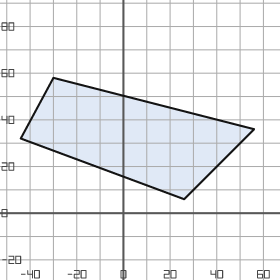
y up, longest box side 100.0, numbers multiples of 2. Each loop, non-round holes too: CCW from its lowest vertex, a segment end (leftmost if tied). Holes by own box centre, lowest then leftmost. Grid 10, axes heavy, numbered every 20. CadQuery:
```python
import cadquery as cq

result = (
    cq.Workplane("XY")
    .moveTo(26.0, 6.0)
    .lineTo(56.0, 36.0)
    .lineTo(-30.0, 58.0)
    .lineTo(-44.0, 32.0)
    .close()
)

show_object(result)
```